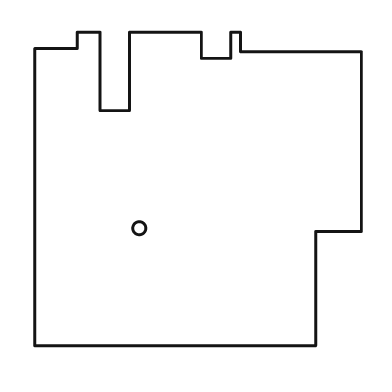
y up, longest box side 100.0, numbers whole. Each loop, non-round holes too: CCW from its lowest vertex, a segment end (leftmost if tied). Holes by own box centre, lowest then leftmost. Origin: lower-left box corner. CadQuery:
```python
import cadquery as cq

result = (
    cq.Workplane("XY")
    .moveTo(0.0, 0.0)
    .lineTo(86.0, 0.0)
    .lineTo(86.0, 35.0)
    .lineTo(100.0, 35.0)
    .lineTo(100.0, 90.0)
    .lineTo(63.0, 90.0)
    .lineTo(63.0, 96.0)
    .lineTo(60.0, 96.0)
    .lineTo(60.0, 88.0)
    .lineTo(51.0, 88.0)
    .lineTo(51.0, 96.0)
    .lineTo(29.0, 96.0)
    .lineTo(29.0, 72.0)
    .lineTo(20.0, 72.0)
    .lineTo(20.0, 96.0)
    .lineTo(13.0, 96.0)
    .lineTo(13.0, 91.0)
    .lineTo(0.0, 91.0)
    .close()
    .moveTo(32.0, 36.0)
    .circle(2.0)
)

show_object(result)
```